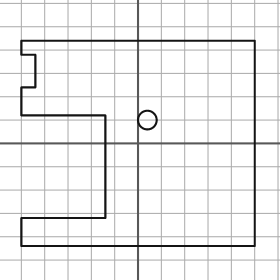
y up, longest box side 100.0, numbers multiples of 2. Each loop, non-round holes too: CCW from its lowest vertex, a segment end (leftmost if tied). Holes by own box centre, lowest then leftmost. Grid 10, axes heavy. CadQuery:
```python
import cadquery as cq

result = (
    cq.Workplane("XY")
    .moveTo(-50.0, -44.0)
    .lineTo(50.0, -44.0)
    .lineTo(50.0, 44.0)
    .lineTo(-50.0, 44.0)
    .lineTo(-50.0, 38.0)
    .lineTo(-44.0, 38.0)
    .lineTo(-44.0, 24.0)
    .lineTo(-50.0, 24.0)
    .lineTo(-50.0, 12.0)
    .lineTo(-14.0, 12.0)
    .lineTo(-14.0, -32.0)
    .lineTo(-50.0, -32.0)
    .close()
    .moveTo(4.0, 10.0)
    .circle(4.0)
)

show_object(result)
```